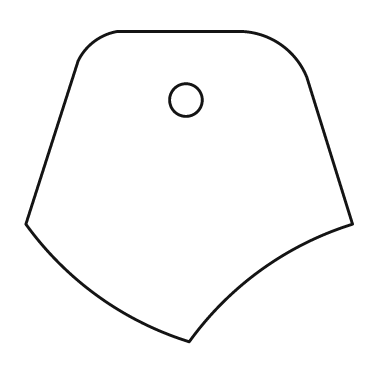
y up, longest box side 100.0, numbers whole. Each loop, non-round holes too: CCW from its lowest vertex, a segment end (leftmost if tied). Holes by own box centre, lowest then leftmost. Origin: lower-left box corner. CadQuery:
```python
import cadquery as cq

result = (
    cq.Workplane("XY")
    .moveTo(50.0, 0.0)
    .threePointArc((72.0, 22.0), (100.0, 36.0))
    .lineTo(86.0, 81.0)
    .threePointArc((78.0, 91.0), (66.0, 95.0))
    .lineTo(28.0, 95.0)
    .threePointArc((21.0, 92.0), (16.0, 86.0))
    .lineTo(0.0, 36.0)
    .threePointArc((22.0, 14.0), (50.0, 0.0))
    .close()
    .moveTo(49.0, 74.0)
    .circle(5.0)
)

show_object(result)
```